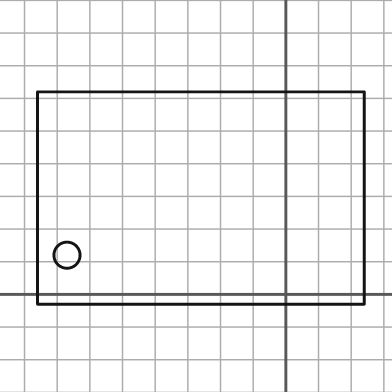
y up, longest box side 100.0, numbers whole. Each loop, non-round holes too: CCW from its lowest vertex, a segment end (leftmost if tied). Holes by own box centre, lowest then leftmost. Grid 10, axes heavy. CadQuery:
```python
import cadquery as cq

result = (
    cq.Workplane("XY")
    .moveTo(-76.0, -3.0)
    .lineTo(24.0, -3.0)
    .lineTo(24.0, 62.0)
    .lineTo(-76.0, 62.0)
    .close()
    .moveTo(-67.0, 12.0)
    .circle(4.0)
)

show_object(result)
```